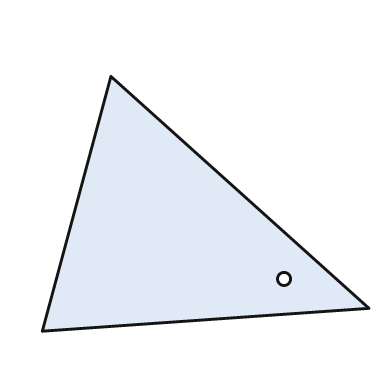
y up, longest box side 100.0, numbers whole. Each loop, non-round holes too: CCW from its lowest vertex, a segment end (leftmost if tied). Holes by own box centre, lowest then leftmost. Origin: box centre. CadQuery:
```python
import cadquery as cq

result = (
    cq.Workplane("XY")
    .moveTo(-50.0, -39.0)
    .lineTo(50.0, -32.0)
    .lineTo(-29.0, 39.0)
    .close()
    .moveTo(24.0, -23.0)
    .circle(2.0)
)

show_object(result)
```